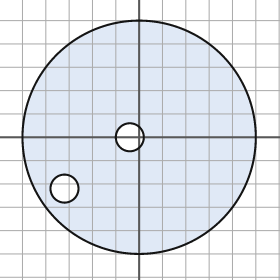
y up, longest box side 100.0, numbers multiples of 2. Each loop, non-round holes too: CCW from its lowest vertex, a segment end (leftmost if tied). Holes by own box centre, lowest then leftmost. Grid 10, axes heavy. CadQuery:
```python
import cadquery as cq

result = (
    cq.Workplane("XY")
    .moveTo(0.0, 0.0)
    .circle(50.0)
    .moveTo(-32.0, -22.0)
    .circle(6.0)
    .moveTo(-4.0, 0.0)
    .circle(6.0)
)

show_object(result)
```